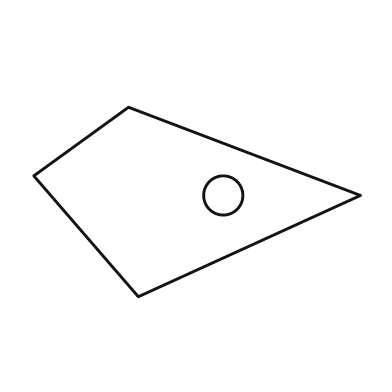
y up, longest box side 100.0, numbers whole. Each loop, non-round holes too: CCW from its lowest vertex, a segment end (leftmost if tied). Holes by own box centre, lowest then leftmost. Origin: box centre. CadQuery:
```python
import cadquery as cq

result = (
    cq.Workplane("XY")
    .moveTo(-18.0, -29.0)
    .lineTo(50.0, 2.0)
    .lineTo(-21.0, 29.0)
    .lineTo(-50.0, 8.0)
    .close()
    .moveTo(8.0, 2.0)
    .circle(6.0)
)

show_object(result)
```